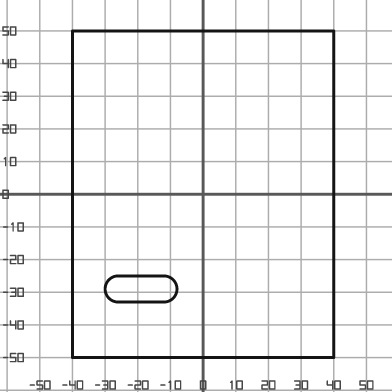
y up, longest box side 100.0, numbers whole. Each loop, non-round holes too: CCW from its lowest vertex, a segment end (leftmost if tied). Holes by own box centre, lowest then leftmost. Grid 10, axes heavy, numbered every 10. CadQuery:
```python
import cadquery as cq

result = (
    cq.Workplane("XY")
    .moveTo(-40.0, -50.0)
    .lineTo(40.0, -50.0)
    .lineTo(40.0, 50.0)
    .lineTo(-40.0, 50.0)
    .close()
    .moveTo(-26.0, -33.0)
    .lineTo(-12.0, -33.0)
    .threePointArc((-8.0, -29.0), (-12.0, -25.0))
    .lineTo(-26.0, -25.0)
    .threePointArc((-30.0, -29.0), (-26.0, -33.0))
    .close()
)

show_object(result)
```